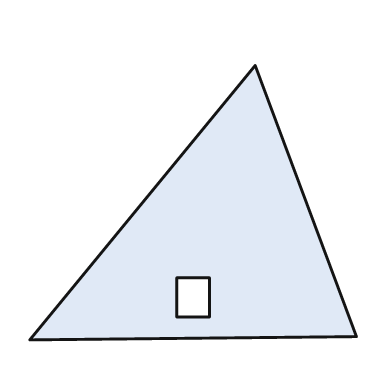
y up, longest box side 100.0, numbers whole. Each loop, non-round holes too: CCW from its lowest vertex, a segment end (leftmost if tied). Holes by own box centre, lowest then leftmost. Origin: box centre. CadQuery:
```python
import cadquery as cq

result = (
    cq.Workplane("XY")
    .moveTo(-50.0, -42.0)
    .lineTo(50.0, -41.0)
    .lineTo(19.0, 42.0)
    .close()
    .moveTo(-5.0, -35.0)
    .lineTo(5.0, -35.0)
    .lineTo(5.0, -23.0)
    .lineTo(-5.0, -23.0)
    .close()
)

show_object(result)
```